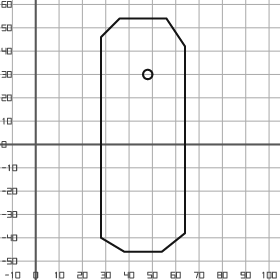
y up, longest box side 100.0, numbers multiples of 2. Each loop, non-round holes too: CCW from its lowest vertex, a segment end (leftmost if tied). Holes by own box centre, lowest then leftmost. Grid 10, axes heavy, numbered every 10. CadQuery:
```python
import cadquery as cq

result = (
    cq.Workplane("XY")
    .moveTo(38.0, -46.0)
    .lineTo(54.0, -46.0)
    .lineTo(64.0, -38.0)
    .lineTo(64.0, 42.0)
    .lineTo(56.0, 54.0)
    .lineTo(36.0, 54.0)
    .lineTo(28.0, 46.0)
    .lineTo(28.0, -40.0)
    .close()
    .moveTo(48.0, 30.0)
    .circle(2.0)
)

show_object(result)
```